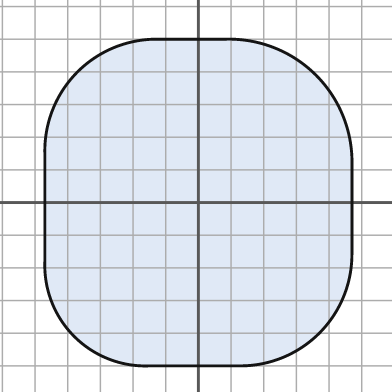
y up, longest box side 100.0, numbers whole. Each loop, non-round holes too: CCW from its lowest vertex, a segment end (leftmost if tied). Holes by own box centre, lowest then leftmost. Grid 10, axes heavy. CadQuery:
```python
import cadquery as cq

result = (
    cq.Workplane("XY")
    .moveTo(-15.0, -50.0)
    .lineTo(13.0, -50.0)
    .threePointArc((37.0, -40.0), (47.0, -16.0))
    .lineTo(47.0, 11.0)
    .threePointArc((36.0, 39.0), (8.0, 50.0))
    .lineTo(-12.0, 50.0)
    .threePointArc((-37.0, 40.0), (-47.0, 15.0))
    .lineTo(-47.0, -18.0)
    .threePointArc((-38.0, -41.0), (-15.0, -50.0))
    .close()
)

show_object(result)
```